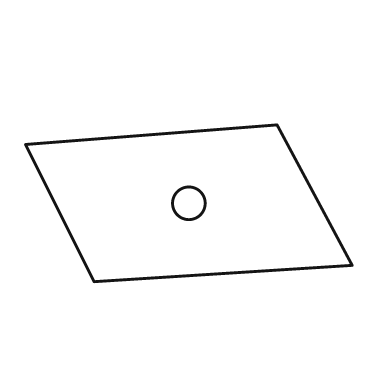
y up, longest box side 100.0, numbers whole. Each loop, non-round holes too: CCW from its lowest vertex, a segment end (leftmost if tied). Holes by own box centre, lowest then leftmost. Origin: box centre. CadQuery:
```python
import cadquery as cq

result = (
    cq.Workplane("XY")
    .moveTo(-29.0, -24.0)
    .lineTo(50.0, -19.0)
    .lineTo(27.0, 24.0)
    .lineTo(-50.0, 18.0)
    .close()
    .moveTo(0.0, 0.0)
    .circle(5.0)
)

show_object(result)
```